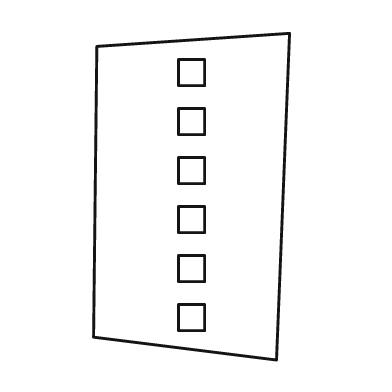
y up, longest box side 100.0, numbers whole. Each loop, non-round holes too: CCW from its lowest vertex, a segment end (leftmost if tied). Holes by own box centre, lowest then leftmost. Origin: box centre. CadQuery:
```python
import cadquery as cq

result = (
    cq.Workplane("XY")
    .moveTo(26.0, -50.0)
    .lineTo(30.0, 50.0)
    .lineTo(-29.0, 46.0)
    .lineTo(-30.0, -43.0)
    .close()
    .moveTo(-4.0, -41.0)
    .lineTo(4.0, -41.0)
    .lineTo(4.0, -33.0)
    .lineTo(-4.0, -33.0)
    .close()
    .moveTo(-4.0, -26.0)
    .lineTo(4.0, -26.0)
    .lineTo(4.0, -18.0)
    .lineTo(-4.0, -18.0)
    .close()
    .moveTo(-4.0, -11.0)
    .lineTo(4.0, -11.0)
    .lineTo(4.0, -3.0)
    .lineTo(-4.0, -3.0)
    .close()
    .moveTo(-4.0, 4.0)
    .lineTo(4.0, 4.0)
    .lineTo(4.0, 12.0)
    .lineTo(-4.0, 12.0)
    .close()
    .moveTo(-4.0, 19.0)
    .lineTo(4.0, 19.0)
    .lineTo(4.0, 27.0)
    .lineTo(-4.0, 27.0)
    .close()
    .moveTo(-4.0, 34.0)
    .lineTo(4.0, 34.0)
    .lineTo(4.0, 42.0)
    .lineTo(-4.0, 42.0)
    .close()
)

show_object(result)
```